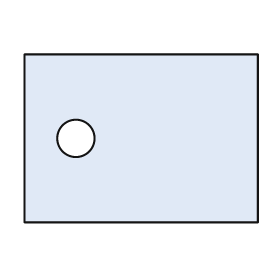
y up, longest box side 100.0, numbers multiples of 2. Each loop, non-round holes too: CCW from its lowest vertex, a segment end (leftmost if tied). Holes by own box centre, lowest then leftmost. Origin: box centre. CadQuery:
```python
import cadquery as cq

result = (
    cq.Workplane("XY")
    .moveTo(-50.0, -36.0)
    .lineTo(50.0, -36.0)
    .lineTo(50.0, 36.0)
    .lineTo(-50.0, 36.0)
    .close()
    .moveTo(-28.0, 0.0)
    .circle(8.0)
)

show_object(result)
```